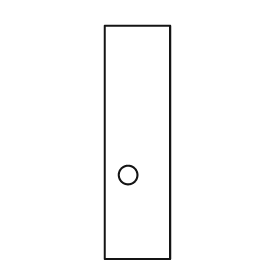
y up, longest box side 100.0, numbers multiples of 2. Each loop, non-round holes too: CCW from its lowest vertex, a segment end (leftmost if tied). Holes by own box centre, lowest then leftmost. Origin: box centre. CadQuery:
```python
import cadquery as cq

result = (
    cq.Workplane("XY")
    .moveTo(-14.0, -50.0)
    .lineTo(14.0, -50.0)
    .lineTo(14.0, 50.0)
    .lineTo(-14.0, 50.0)
    .close()
    .moveTo(-4.0, -14.0)
    .circle(4.0)
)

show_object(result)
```